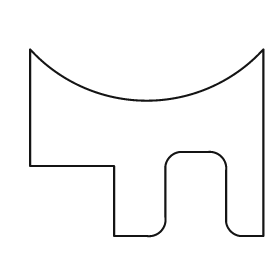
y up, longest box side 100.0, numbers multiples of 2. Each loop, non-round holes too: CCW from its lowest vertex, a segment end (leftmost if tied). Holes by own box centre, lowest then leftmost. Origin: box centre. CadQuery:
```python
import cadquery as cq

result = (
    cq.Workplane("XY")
    .moveTo(-14.0, -40.0)
    .lineTo(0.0, -40.0)
    .threePointArc((6.0, -38.0), (8.0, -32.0))
    .lineTo(8.0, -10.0)
    .threePointArc((10.0, -6.0), (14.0, -4.0))
    .lineTo(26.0, -4.0)
    .threePointArc((32.0, -6.0), (34.0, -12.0))
    .lineTo(34.0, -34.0)
    .threePointArc((36.0, -38.0), (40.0, -40.0))
    .lineTo(50.0, -40.0)
    .lineTo(50.0, 40.0)
    .threePointArc((0.0, 18.0), (-50.0, 40.0))
    .lineTo(-50.0, -10.0)
    .lineTo(-14.0, -10.0)
    .close()
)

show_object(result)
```